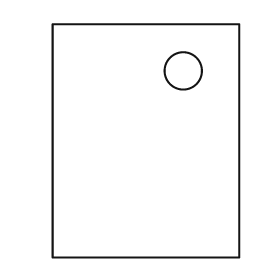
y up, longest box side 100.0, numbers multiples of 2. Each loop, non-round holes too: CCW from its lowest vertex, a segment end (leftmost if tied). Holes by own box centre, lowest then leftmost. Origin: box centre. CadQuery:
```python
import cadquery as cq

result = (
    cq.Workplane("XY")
    .moveTo(-40.0, -50.0)
    .lineTo(40.0, -50.0)
    .lineTo(40.0, 50.0)
    .lineTo(-40.0, 50.0)
    .close()
    .moveTo(16.0, 30.0)
    .circle(8.0)
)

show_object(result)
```